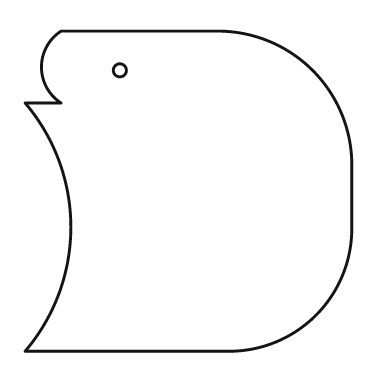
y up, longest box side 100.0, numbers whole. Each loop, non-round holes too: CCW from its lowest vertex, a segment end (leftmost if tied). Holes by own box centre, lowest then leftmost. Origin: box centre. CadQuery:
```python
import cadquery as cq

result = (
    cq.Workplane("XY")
    .moveTo(-50.0, -49.0)
    .lineTo(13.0, -49.0)
    .threePointArc((39.0, -38.0), (50.0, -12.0))
    .lineTo(50.0, 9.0)
    .threePointArc((38.0, 37.0), (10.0, 49.0))
    .lineTo(-39.0, 49.0)
    .threePointArc((-45.0, 38.0), (-39.0, 27.0))
    .lineTo(-50.0, 27.0)
    .threePointArc((-36.0, -11.0), (-50.0, -49.0))
    .close()
    .moveTo(-21.0, 37.0)
    .circle(2.0)
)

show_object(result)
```